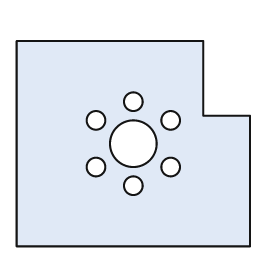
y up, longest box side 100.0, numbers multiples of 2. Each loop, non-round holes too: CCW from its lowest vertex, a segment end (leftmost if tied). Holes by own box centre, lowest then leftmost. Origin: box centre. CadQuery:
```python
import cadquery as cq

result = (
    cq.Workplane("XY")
    .moveTo(-50.0, -44.0)
    .lineTo(50.0, -44.0)
    .lineTo(50.0, 12.0)
    .lineTo(30.0, 12.0)
    .lineTo(30.0, 44.0)
    .lineTo(-50.0, 44.0)
    .close()
    .moveTo(0.0, -18.0)
    .circle(4.0)
    .moveTo(-16.0, -10.0)
    .circle(4.0)
    .moveTo(16.0, -10.0)
    .circle(4.0)
    .moveTo(0.0, 0.0)
    .circle(10.0)
    .moveTo(-16.0, 10.0)
    .circle(4.0)
    .moveTo(16.0, 10.0)
    .circle(4.0)
    .moveTo(0.0, 18.0)
    .circle(4.0)
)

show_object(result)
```